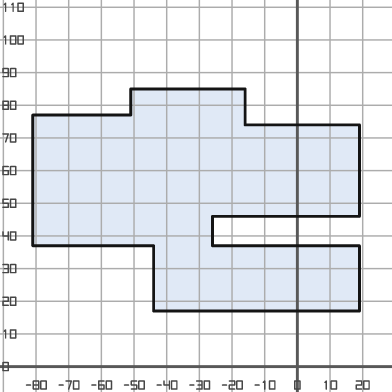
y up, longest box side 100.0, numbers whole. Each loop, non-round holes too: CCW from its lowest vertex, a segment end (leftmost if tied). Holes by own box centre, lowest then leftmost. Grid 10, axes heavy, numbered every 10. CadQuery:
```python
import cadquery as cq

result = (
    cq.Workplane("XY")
    .moveTo(-44.0, 17.0)
    .lineTo(19.0, 17.0)
    .lineTo(19.0, 37.0)
    .lineTo(-26.0, 37.0)
    .lineTo(-26.0, 46.0)
    .lineTo(19.0, 46.0)
    .lineTo(19.0, 74.0)
    .lineTo(-16.0, 74.0)
    .lineTo(-16.0, 85.0)
    .lineTo(-51.0, 85.0)
    .lineTo(-51.0, 77.0)
    .lineTo(-81.0, 77.0)
    .lineTo(-81.0, 37.0)
    .lineTo(-44.0, 37.0)
    .close()
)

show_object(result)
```